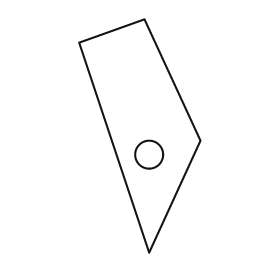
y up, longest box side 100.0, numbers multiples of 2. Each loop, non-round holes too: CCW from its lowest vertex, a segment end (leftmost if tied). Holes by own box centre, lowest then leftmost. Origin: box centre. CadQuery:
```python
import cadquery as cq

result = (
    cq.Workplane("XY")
    .moveTo(4.0, -50.0)
    .lineTo(26.0, -2.0)
    .lineTo(2.0, 50.0)
    .lineTo(-26.0, 40.0)
    .close()
    .moveTo(4.0, -8.0)
    .circle(6.0)
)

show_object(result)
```